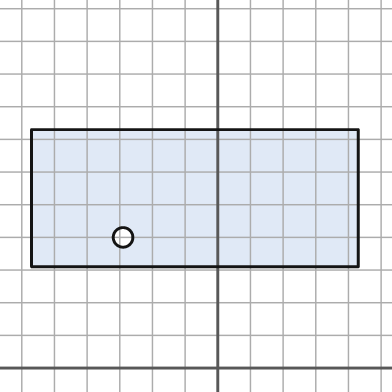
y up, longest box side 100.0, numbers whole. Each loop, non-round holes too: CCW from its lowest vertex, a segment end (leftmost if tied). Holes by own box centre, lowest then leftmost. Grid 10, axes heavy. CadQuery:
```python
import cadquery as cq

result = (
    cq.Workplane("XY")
    .moveTo(-57.0, 31.0)
    .lineTo(43.0, 31.0)
    .lineTo(43.0, 73.0)
    .lineTo(-57.0, 73.0)
    .close()
    .moveTo(-29.0, 40.0)
    .circle(3.0)
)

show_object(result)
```